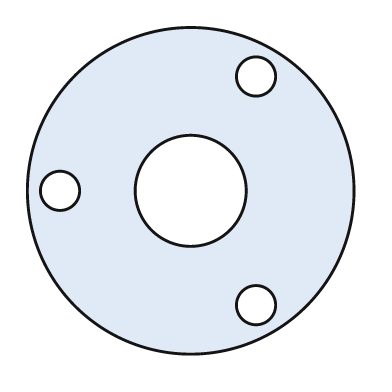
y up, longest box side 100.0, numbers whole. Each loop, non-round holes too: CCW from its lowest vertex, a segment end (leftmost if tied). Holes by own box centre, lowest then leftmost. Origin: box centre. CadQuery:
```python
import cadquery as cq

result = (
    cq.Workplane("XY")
    .moveTo(0.0, 0.0)
    .circle(50.0)
    .moveTo(20.0, -35.0)
    .circle(6.0)
    .moveTo(-40.0, 0.0)
    .circle(6.0)
    .moveTo(0.0, 0.0)
    .circle(17.0)
    .moveTo(20.0, 35.0)
    .circle(6.0)
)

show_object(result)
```